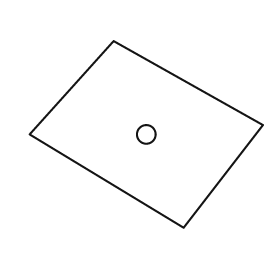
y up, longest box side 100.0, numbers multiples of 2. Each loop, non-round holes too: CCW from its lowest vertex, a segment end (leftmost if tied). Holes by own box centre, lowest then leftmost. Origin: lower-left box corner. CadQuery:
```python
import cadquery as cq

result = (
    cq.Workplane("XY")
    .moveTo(66.0, 0.0)
    .lineTo(100.0, 44.0)
    .lineTo(36.0, 80.0)
    .lineTo(0.0, 40.0)
    .close()
    .moveTo(50.0, 40.0)
    .circle(4.0)
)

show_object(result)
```